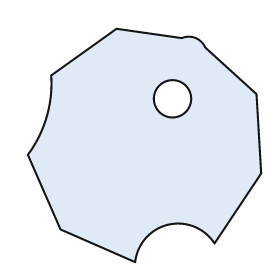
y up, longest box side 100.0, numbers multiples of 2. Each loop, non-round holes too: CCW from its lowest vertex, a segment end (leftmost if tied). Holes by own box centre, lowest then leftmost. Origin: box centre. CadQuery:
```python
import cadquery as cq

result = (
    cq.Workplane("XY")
    .moveTo(-4.0, -50.0)
    .threePointArc((10.0, -34.0), (30.0, -42.0))
    .lineTo(50.0, -12.0)
    .lineTo(48.0, 22.0)
    .lineTo(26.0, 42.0)
    .threePointArc((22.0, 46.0), (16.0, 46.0))
    .lineTo(-12.0, 50.0)
    .lineTo(-40.0, 30.0)
    .threePointArc((-42.0, 12.0), (-50.0, -4.0))
    .lineTo(-36.0, -36.0)
    .close()
    .moveTo(12.0, 20.0)
    .circle(8.0)
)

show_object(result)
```